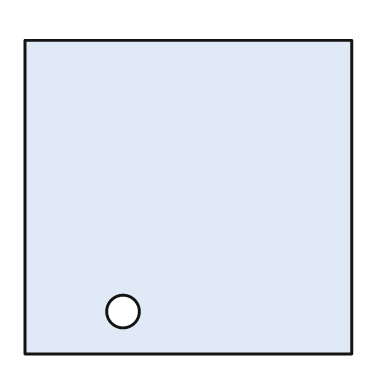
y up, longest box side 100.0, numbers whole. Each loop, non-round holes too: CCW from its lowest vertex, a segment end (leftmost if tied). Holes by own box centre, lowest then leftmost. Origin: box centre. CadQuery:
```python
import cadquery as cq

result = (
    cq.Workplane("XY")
    .moveTo(-50.0, -48.0)
    .lineTo(50.0, -48.0)
    .lineTo(50.0, 48.0)
    .lineTo(-50.0, 48.0)
    .close()
    .moveTo(-20.0, -35.0)
    .circle(5.0)
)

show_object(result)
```